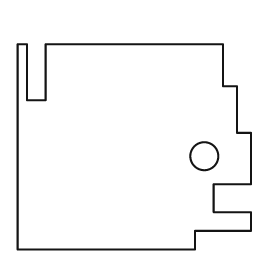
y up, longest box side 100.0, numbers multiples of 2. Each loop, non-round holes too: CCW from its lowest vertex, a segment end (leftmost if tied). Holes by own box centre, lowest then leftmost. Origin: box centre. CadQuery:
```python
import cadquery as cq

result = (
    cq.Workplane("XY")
    .moveTo(-50.0, -44.0)
    .lineTo(26.0, -44.0)
    .lineTo(26.0, -36.0)
    .lineTo(50.0, -36.0)
    .lineTo(50.0, -28.0)
    .lineTo(34.0, -28.0)
    .lineTo(34.0, -16.0)
    .lineTo(50.0, -16.0)
    .lineTo(50.0, 6.0)
    .lineTo(44.0, 6.0)
    .lineTo(44.0, 26.0)
    .lineTo(38.0, 26.0)
    .lineTo(38.0, 44.0)
    .lineTo(-38.0, 44.0)
    .lineTo(-38.0, 20.0)
    .lineTo(-46.0, 20.0)
    .lineTo(-46.0, 44.0)
    .lineTo(-50.0, 44.0)
    .close()
    .moveTo(30.0, -4.0)
    .circle(6.0)
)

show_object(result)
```